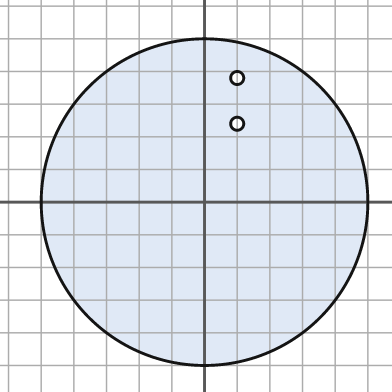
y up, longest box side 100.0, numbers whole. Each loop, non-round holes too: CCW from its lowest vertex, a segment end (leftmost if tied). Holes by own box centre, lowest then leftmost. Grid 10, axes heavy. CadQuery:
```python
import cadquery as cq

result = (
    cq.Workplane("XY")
    .moveTo(0.0, 0.0)
    .circle(50.0)
    .moveTo(10.0, 24.0)
    .circle(2.0)
    .moveTo(10.0, 38.0)
    .circle(2.0)
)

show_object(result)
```